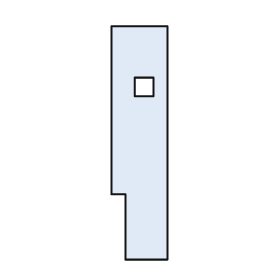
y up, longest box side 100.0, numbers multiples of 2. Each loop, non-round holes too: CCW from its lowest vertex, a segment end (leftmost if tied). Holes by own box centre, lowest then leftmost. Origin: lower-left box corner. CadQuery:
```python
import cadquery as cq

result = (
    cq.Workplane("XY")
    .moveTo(6.0, 0.0)
    .lineTo(24.0, 0.0)
    .lineTo(24.0, 100.0)
    .lineTo(0.0, 100.0)
    .lineTo(0.0, 28.0)
    .lineTo(6.0, 28.0)
    .close()
    .moveTo(10.0, 70.0)
    .lineTo(18.0, 70.0)
    .lineTo(18.0, 78.0)
    .lineTo(10.0, 78.0)
    .close()
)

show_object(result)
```